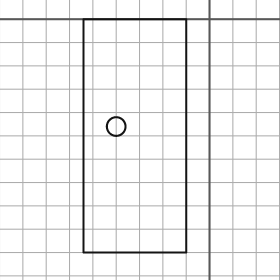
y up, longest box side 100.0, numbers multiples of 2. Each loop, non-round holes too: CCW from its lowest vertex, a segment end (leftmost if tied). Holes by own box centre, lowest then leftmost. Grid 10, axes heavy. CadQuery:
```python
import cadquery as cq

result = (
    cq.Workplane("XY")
    .moveTo(-54.0, -100.0)
    .lineTo(-10.0, -100.0)
    .lineTo(-10.0, 0.0)
    .lineTo(-54.0, 0.0)
    .close()
    .moveTo(-40.0, -46.0)
    .circle(4.0)
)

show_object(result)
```